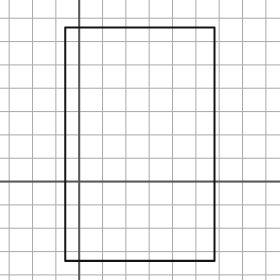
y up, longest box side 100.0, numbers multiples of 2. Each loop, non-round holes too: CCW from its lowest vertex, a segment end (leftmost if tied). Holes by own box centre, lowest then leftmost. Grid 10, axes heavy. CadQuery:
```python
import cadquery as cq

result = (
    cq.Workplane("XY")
    .moveTo(-6.0, -34.0)
    .lineTo(58.0, -34.0)
    .lineTo(58.0, 66.0)
    .lineTo(-6.0, 66.0)
    .close()
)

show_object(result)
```